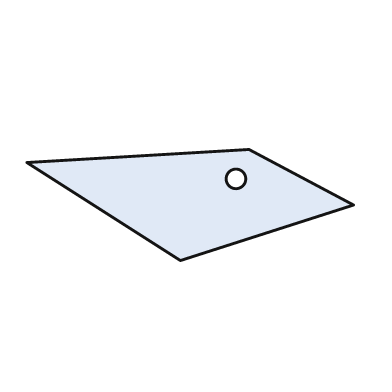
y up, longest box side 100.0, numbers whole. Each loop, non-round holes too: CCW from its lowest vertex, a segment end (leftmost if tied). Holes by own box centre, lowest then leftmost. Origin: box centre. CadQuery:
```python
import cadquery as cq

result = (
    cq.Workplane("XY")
    .moveTo(-3.0, -17.0)
    .lineTo(50.0, 0.0)
    .lineTo(18.0, 17.0)
    .lineTo(-50.0, 13.0)
    .close()
    .moveTo(14.0, 8.0)
    .circle(3.0)
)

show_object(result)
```